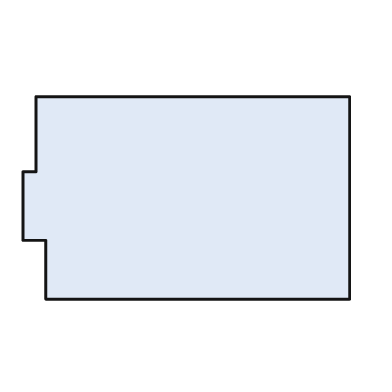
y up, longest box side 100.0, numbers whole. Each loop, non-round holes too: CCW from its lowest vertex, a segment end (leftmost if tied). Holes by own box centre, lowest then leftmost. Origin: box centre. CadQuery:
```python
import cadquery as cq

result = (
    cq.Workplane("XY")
    .moveTo(-43.0, -31.0)
    .lineTo(50.0, -31.0)
    .lineTo(50.0, 31.0)
    .lineTo(-46.0, 31.0)
    .lineTo(-46.0, 8.0)
    .lineTo(-50.0, 8.0)
    .lineTo(-50.0, -13.0)
    .lineTo(-43.0, -13.0)
    .close()
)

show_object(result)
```